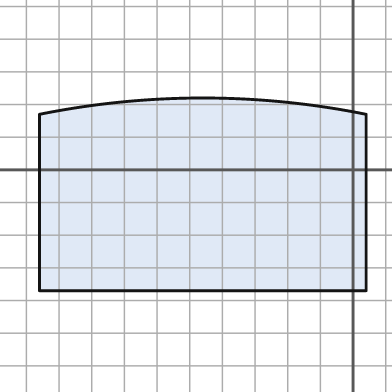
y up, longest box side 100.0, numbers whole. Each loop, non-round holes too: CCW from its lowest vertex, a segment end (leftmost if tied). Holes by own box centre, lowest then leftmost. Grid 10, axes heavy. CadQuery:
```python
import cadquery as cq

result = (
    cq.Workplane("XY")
    .moveTo(-96.0, -37.0)
    .lineTo(4.0, -37.0)
    .lineTo(4.0, 17.0)
    .threePointArc((-46.0, 22.0), (-96.0, 17.0))
    .close()
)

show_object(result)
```